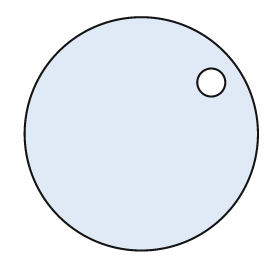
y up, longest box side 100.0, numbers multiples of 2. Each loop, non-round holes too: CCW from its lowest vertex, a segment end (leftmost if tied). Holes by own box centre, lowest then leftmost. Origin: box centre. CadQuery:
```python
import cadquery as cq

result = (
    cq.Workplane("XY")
    .moveTo(0.0, 0.0)
    .circle(50.0)
    .moveTo(30.0, 22.0)
    .circle(6.0)
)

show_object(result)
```